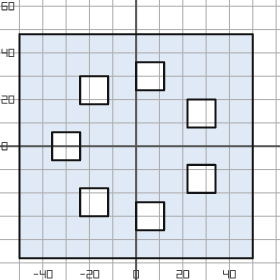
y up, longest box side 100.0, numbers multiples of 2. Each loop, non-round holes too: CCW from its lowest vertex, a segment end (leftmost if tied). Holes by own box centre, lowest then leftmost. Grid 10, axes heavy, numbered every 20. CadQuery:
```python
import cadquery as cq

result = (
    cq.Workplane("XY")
    .moveTo(-50.0, -48.0)
    .lineTo(50.0, -48.0)
    .lineTo(50.0, 48.0)
    .lineTo(-50.0, 48.0)
    .close()
    .moveTo(0.0, -36.0)
    .lineTo(12.0, -36.0)
    .lineTo(12.0, -24.0)
    .lineTo(0.0, -24.0)
    .close()
    .moveTo(-24.0, -30.0)
    .lineTo(-12.0, -30.0)
    .lineTo(-12.0, -18.0)
    .lineTo(-24.0, -18.0)
    .close()
    .moveTo(22.0, -20.0)
    .lineTo(34.0, -20.0)
    .lineTo(34.0, -8.0)
    .lineTo(22.0, -8.0)
    .close()
    .moveTo(-36.0, -6.0)
    .lineTo(-24.0, -6.0)
    .lineTo(-24.0, 6.0)
    .lineTo(-36.0, 6.0)
    .close()
    .moveTo(22.0, 8.0)
    .lineTo(34.0, 8.0)
    .lineTo(34.0, 20.0)
    .lineTo(22.0, 20.0)
    .close()
    .moveTo(-24.0, 18.0)
    .lineTo(-12.0, 18.0)
    .lineTo(-12.0, 30.0)
    .lineTo(-24.0, 30.0)
    .close()
    .moveTo(0.0, 24.0)
    .lineTo(12.0, 24.0)
    .lineTo(12.0, 36.0)
    .lineTo(0.0, 36.0)
    .close()
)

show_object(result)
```